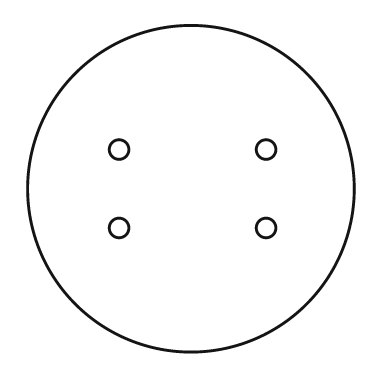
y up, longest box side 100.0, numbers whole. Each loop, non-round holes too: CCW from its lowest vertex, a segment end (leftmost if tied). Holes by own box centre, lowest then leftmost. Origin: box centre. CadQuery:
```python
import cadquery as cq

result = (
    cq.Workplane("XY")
    .moveTo(0.0, 0.0)
    .circle(50.0)
    .moveTo(-22.0, -12.0)
    .circle(3.0)
    .moveTo(23.0, -12.0)
    .circle(3.0)
    .moveTo(-22.0, 12.0)
    .circle(3.0)
    .moveTo(23.0, 12.0)
    .circle(3.0)
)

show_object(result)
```